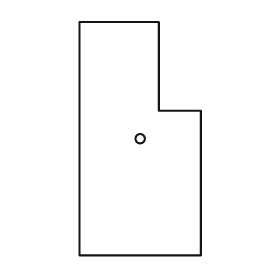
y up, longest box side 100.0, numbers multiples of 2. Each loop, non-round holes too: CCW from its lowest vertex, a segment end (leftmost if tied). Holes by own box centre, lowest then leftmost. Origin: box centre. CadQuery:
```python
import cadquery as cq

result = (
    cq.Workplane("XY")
    .moveTo(-26.0, -50.0)
    .lineTo(26.0, -50.0)
    .lineTo(26.0, 12.0)
    .lineTo(8.0, 12.0)
    .lineTo(8.0, 50.0)
    .lineTo(-26.0, 50.0)
    .close()
    .moveTo(0.0, 0.0)
    .circle(2.0)
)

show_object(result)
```